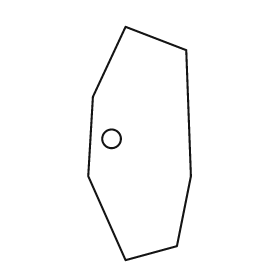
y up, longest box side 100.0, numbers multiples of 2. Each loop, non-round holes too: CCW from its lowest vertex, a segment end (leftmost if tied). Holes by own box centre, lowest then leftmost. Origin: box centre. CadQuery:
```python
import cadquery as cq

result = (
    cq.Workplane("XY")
    .moveTo(-6.0, -50.0)
    .lineTo(16.0, -44.0)
    .lineTo(22.0, -14.0)
    .lineTo(20.0, 40.0)
    .lineTo(-6.0, 50.0)
    .lineTo(-20.0, 20.0)
    .lineTo(-22.0, -14.0)
    .close()
    .moveTo(-12.0, 2.0)
    .circle(4.0)
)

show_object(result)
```